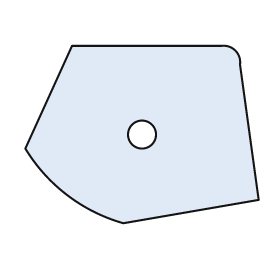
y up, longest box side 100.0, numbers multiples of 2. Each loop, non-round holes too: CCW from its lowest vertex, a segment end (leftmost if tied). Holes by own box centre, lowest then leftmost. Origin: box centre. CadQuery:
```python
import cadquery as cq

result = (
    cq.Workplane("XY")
    .moveTo(-8.0, -38.0)
    .lineTo(50.0, -28.0)
    .lineTo(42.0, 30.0)
    .threePointArc((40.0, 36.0), (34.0, 38.0))
    .lineTo(-30.0, 38.0)
    .lineTo(-50.0, -6.0)
    .threePointArc((-32.0, -26.0), (-8.0, -38.0))
    .close()
    .moveTo(0.0, 0.0)
    .circle(6.0)
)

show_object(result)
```